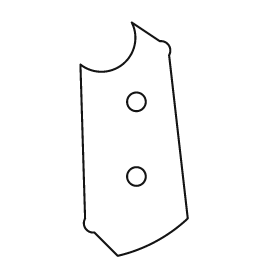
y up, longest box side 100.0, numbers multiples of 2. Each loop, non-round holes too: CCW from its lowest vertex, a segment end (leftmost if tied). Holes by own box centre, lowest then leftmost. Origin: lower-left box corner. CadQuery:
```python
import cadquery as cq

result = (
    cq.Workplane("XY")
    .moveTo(16.0, 0.0)
    .threePointArc((32.0, 6.0), (46.0, 16.0))
    .lineTo(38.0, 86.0)
    .threePointArc((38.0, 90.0), (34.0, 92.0))
    .lineTo(22.0, 100.0)
    .threePointArc((18.0, 82.0), (0.0, 82.0))
    .lineTo(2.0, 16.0)
    .threePointArc((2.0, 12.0), (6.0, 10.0))
    .close()
    .moveTo(24.0, 34.0)
    .circle(4.0)
    .moveTo(24.0, 66.0)
    .circle(4.0)
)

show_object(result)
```